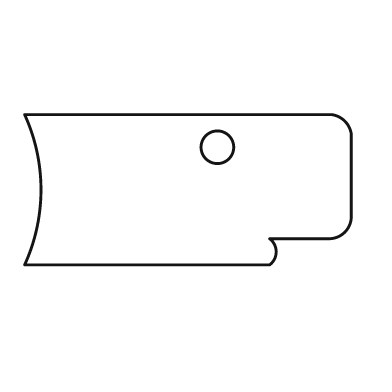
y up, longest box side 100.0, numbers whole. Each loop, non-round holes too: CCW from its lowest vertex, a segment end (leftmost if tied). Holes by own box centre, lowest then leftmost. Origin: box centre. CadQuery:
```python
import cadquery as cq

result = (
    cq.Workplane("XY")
    .moveTo(-50.0, -23.0)
    .lineTo(25.0, -23.0)
    .threePointArc((27.0, -19.0), (25.0, -15.0))
    .lineTo(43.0, -15.0)
    .threePointArc((48.0, -13.0), (50.0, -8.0))
    .lineTo(50.0, 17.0)
    .threePointArc((48.0, 21.0), (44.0, 23.0))
    .lineTo(-50.0, 23.0)
    .threePointArc((-45.0, 0.0), (-50.0, -23.0))
    .close()
    .moveTo(9.0, 13.0)
    .circle(5.0)
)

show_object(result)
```